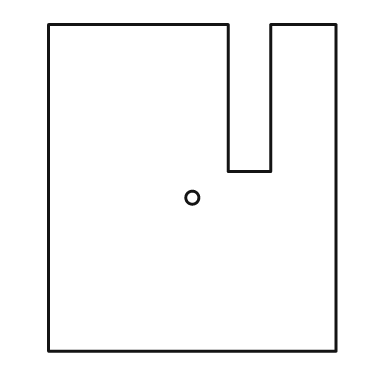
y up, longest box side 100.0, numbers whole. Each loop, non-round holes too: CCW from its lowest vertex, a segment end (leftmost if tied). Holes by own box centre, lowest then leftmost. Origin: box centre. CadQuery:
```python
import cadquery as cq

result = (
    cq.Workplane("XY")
    .moveTo(-44.0, -50.0)
    .lineTo(44.0, -50.0)
    .lineTo(44.0, 50.0)
    .lineTo(24.0, 50.0)
    .lineTo(24.0, 5.0)
    .lineTo(11.0, 5.0)
    .lineTo(11.0, 50.0)
    .lineTo(-44.0, 50.0)
    .close()
    .moveTo(0.0, -3.0)
    .circle(2.0)
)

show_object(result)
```